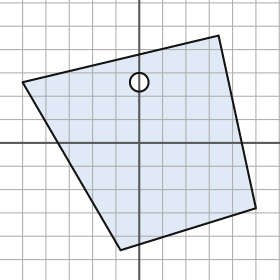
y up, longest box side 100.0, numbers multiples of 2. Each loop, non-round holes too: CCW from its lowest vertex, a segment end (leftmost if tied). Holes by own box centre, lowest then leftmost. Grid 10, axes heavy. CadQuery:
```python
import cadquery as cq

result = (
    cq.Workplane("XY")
    .moveTo(-8.0, -46.0)
    .lineTo(50.0, -28.0)
    .lineTo(34.0, 46.0)
    .lineTo(-50.0, 26.0)
    .close()
    .moveTo(0.0, 26.0)
    .circle(4.0)
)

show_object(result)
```